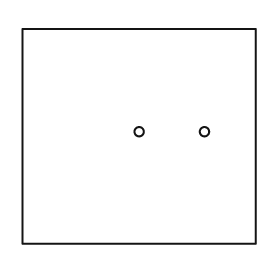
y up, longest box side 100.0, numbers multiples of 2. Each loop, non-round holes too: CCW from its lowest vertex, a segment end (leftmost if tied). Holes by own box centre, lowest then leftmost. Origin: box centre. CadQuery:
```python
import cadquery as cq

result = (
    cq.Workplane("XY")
    .moveTo(-50.0, -46.0)
    .lineTo(50.0, -46.0)
    .lineTo(50.0, 46.0)
    .lineTo(-50.0, 46.0)
    .close()
    .moveTo(0.0, 2.0)
    .circle(2.0)
    .moveTo(28.0, 2.0)
    .circle(2.0)
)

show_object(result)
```